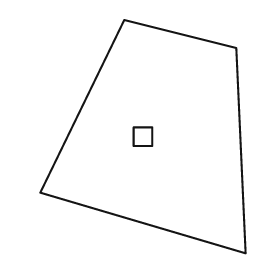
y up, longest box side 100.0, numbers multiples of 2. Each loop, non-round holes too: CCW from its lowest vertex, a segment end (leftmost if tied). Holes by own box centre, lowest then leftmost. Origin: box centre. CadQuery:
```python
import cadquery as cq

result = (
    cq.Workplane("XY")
    .moveTo(44.0, -50.0)
    .lineTo(40.0, 38.0)
    .lineTo(-8.0, 50.0)
    .lineTo(-44.0, -24.0)
    .close()
    .moveTo(-4.0, -4.0)
    .lineTo(4.0, -4.0)
    .lineTo(4.0, 4.0)
    .lineTo(-4.0, 4.0)
    .close()
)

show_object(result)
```